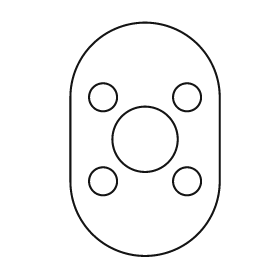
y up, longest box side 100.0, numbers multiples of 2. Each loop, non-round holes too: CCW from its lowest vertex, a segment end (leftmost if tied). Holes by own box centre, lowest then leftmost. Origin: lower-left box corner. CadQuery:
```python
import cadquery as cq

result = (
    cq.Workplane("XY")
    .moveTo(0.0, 32.0)
    .threePointArc((32.0, 0.0), (64.0, 32.0))
    .lineTo(64.0, 68.0)
    .threePointArc((32.0, 100.0), (0.0, 68.0))
    .close()
    .moveTo(14.0, 32.0)
    .circle(6.0)
    .moveTo(50.0, 32.0)
    .circle(6.0)
    .moveTo(32.0, 50.0)
    .circle(14.0)
    .moveTo(14.0, 68.0)
    .circle(6.0)
    .moveTo(50.0, 68.0)
    .circle(6.0)
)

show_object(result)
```